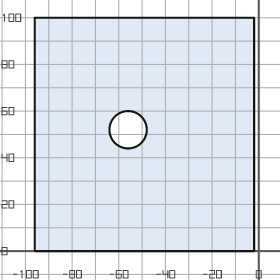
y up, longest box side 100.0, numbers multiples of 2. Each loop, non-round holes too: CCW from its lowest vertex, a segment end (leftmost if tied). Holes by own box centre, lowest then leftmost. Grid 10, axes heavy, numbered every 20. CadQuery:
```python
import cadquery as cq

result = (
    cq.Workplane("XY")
    .moveTo(-96.0, 0.0)
    .lineTo(-2.0, 0.0)
    .lineTo(-2.0, 100.0)
    .lineTo(-96.0, 100.0)
    .close()
    .moveTo(-56.0, 52.0)
    .circle(8.0)
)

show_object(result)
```